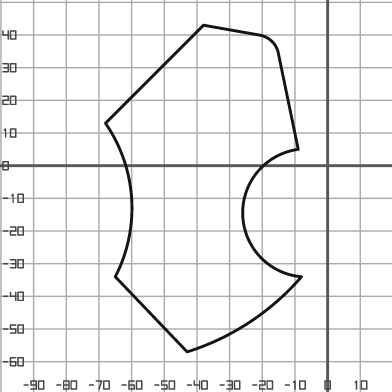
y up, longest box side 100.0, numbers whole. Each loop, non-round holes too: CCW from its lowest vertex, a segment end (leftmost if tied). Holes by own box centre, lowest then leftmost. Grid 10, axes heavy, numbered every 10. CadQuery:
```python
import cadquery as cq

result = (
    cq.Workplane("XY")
    .moveTo(-43.0, -57.0)
    .threePointArc((-24.0, -48.0), (-8.0, -34.0))
    .threePointArc((-26.0, -15.0), (-9.0, 5.0))
    .lineTo(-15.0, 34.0)
    .threePointArc((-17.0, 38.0), (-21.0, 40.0))
    .lineTo(-38.0, 43.0)
    .lineTo(-68.0, 13.0)
    .threePointArc((-60.0, -10.0), (-65.0, -34.0))
    .close()
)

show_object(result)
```